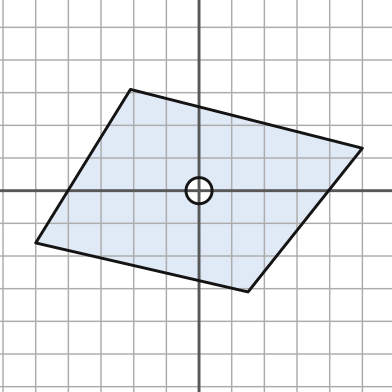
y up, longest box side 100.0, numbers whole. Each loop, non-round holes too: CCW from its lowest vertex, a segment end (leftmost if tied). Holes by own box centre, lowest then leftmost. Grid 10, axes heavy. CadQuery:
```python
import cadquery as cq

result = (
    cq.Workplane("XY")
    .moveTo(15.0, -31.0)
    .lineTo(50.0, 13.0)
    .lineTo(-21.0, 31.0)
    .lineTo(-50.0, -16.0)
    .close()
    .moveTo(0.0, 0.0)
    .circle(4.0)
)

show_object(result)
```